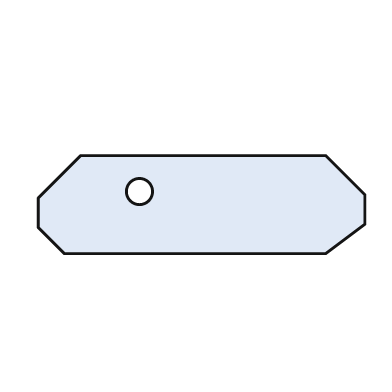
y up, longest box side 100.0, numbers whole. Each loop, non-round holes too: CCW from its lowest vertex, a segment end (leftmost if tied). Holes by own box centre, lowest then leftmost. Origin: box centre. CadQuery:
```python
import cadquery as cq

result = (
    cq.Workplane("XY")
    .moveTo(-42.0, -15.0)
    .lineTo(38.0, -15.0)
    .lineTo(50.0, -6.0)
    .lineTo(50.0, 3.0)
    .lineTo(38.0, 15.0)
    .lineTo(-37.0, 15.0)
    .lineTo(-50.0, 2.0)
    .lineTo(-50.0, -7.0)
    .close()
    .moveTo(-19.0, 4.0)
    .circle(4.0)
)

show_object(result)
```